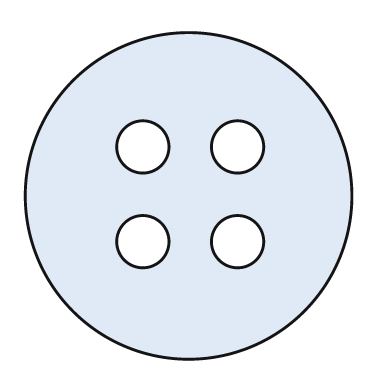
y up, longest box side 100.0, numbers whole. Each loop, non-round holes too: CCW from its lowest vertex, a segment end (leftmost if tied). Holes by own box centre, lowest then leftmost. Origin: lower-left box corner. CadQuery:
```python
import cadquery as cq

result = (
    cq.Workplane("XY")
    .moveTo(50.0, 50.0)
    .circle(50.0)
    .moveTo(36.0, 36.0)
    .circle(8.0)
    .moveTo(65.0, 36.0)
    .circle(8.0)
    .moveTo(36.0, 65.0)
    .circle(8.0)
    .moveTo(65.0, 65.0)
    .circle(8.0)
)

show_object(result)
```